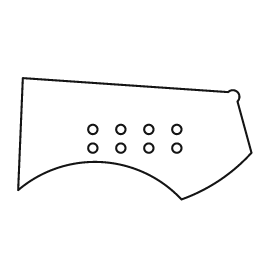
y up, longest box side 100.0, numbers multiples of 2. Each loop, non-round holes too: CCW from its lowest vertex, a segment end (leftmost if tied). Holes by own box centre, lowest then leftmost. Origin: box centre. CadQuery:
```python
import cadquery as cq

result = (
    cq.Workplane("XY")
    .moveTo(20.0, -26.0)
    .threePointArc((36.0, -18.0), (50.0, -6.0))
    .lineTo(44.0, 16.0)
    .threePointArc((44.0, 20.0), (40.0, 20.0))
    .lineTo(-48.0, 26.0)
    .lineTo(-50.0, -22.0)
    .threePointArc((-14.0, -10.0), (20.0, -26.0))
    .close()
    .moveTo(-18.0, -4.0)
    .circle(2.0)
    .moveTo(-6.0, -4.0)
    .circle(2.0)
    .moveTo(6.0, -4.0)
    .circle(2.0)
    .moveTo(18.0, -4.0)
    .circle(2.0)
    .moveTo(-18.0, 4.0)
    .circle(2.0)
    .moveTo(-6.0, 4.0)
    .circle(2.0)
    .moveTo(6.0, 4.0)
    .circle(2.0)
    .moveTo(18.0, 4.0)
    .circle(2.0)
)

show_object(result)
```